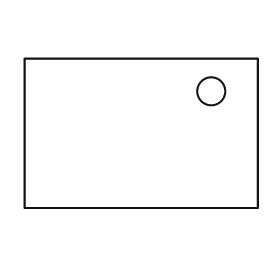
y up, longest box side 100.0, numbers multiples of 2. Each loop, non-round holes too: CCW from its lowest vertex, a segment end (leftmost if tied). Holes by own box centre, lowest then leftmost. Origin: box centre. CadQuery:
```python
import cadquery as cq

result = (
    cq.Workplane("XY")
    .moveTo(-50.0, -32.0)
    .lineTo(50.0, -32.0)
    .lineTo(50.0, 32.0)
    .lineTo(-50.0, 32.0)
    .close()
    .moveTo(30.0, 18.0)
    .circle(6.0)
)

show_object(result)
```